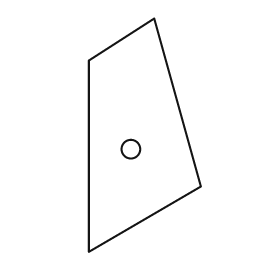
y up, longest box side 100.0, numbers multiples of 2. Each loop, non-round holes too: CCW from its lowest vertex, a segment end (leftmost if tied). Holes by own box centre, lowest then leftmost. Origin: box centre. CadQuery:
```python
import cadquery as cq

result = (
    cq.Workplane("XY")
    .moveTo(-24.0, -50.0)
    .lineTo(24.0, -22.0)
    .lineTo(4.0, 50.0)
    .lineTo(-24.0, 32.0)
    .close()
    .moveTo(-6.0, -6.0)
    .circle(4.0)
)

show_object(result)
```